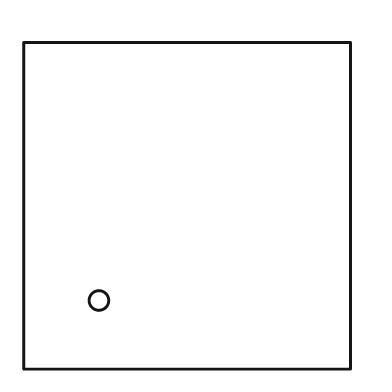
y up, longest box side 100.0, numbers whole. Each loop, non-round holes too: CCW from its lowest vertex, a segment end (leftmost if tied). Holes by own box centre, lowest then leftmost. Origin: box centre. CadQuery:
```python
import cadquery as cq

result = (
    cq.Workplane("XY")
    .moveTo(-50.0, -50.0)
    .lineTo(50.0, -50.0)
    .lineTo(50.0, 50.0)
    .lineTo(-50.0, 50.0)
    .close()
    .moveTo(-27.0, -29.0)
    .circle(3.0)
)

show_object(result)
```